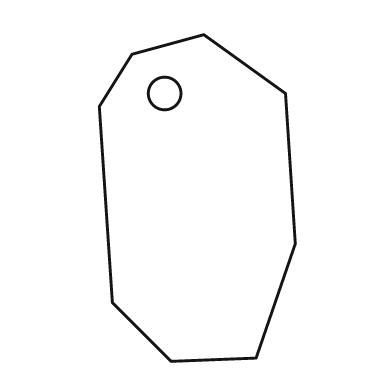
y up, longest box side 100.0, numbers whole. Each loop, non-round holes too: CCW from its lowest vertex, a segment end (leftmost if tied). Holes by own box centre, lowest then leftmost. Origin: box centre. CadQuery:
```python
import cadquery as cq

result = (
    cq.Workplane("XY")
    .moveTo(-8.0, -50.0)
    .lineTo(18.0, -49.0)
    .lineTo(30.0, -14.0)
    .lineTo(27.0, 32.0)
    .lineTo(2.0, 50.0)
    .lineTo(-20.0, 44.0)
    .lineTo(-30.0, 28.0)
    .lineTo(-26.0, -32.0)
    .close()
    .moveTo(-10.0, 32.0)
    .circle(5.0)
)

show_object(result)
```